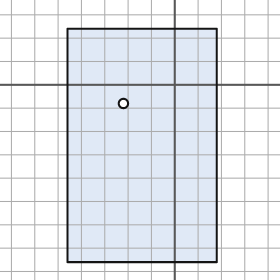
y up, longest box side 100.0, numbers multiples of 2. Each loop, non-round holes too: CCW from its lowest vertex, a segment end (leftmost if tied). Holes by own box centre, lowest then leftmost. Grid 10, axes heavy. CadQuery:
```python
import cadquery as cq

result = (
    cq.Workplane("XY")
    .moveTo(-46.0, -76.0)
    .lineTo(18.0, -76.0)
    .lineTo(18.0, 24.0)
    .lineTo(-46.0, 24.0)
    .close()
    .moveTo(-22.0, -8.0)
    .circle(2.0)
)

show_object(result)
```